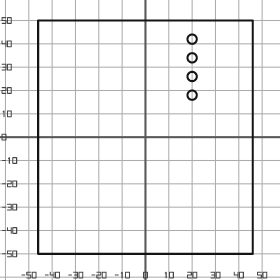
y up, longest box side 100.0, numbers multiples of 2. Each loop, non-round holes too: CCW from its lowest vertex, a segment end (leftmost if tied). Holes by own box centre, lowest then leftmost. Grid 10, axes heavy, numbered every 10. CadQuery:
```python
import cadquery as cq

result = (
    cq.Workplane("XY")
    .moveTo(-46.0, -50.0)
    .lineTo(46.0, -50.0)
    .lineTo(46.0, 50.0)
    .lineTo(-46.0, 50.0)
    .close()
    .moveTo(20.0, 18.0)
    .circle(2.0)
    .moveTo(20.0, 26.0)
    .circle(2.0)
    .moveTo(20.0, 34.0)
    .circle(2.0)
    .moveTo(20.0, 42.0)
    .circle(2.0)
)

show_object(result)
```